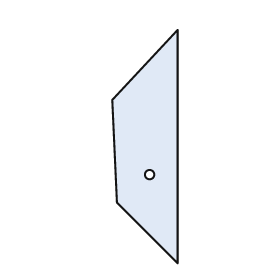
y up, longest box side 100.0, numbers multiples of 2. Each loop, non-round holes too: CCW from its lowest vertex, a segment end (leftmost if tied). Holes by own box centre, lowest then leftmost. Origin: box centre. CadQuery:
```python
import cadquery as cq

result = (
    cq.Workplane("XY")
    .moveTo(14.0, -50.0)
    .lineTo(14.0, 50.0)
    .lineTo(-14.0, 20.0)
    .lineTo(-12.0, -24.0)
    .close()
    .moveTo(2.0, -12.0)
    .circle(2.0)
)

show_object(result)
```